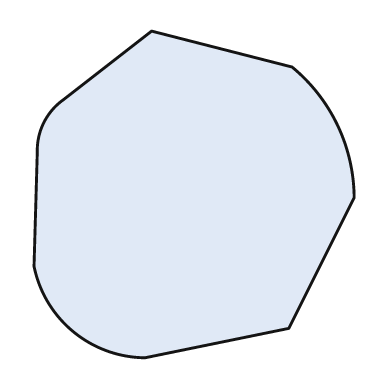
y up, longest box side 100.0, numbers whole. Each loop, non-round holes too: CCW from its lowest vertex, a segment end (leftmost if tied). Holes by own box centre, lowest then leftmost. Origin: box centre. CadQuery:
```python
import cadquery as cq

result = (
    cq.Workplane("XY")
    .moveTo(-15.0, -50.0)
    .lineTo(29.0, -41.0)
    .lineTo(49.0, -1.0)
    .threePointArc((44.0, 21.0), (30.0, 39.0))
    .lineTo(-13.0, 50.0)
    .lineTo(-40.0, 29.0)
    .threePointArc((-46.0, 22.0), (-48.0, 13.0))
    .lineTo(-49.0, -22.0)
    .threePointArc((-37.0, -42.0), (-15.0, -50.0))
    .close()
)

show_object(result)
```